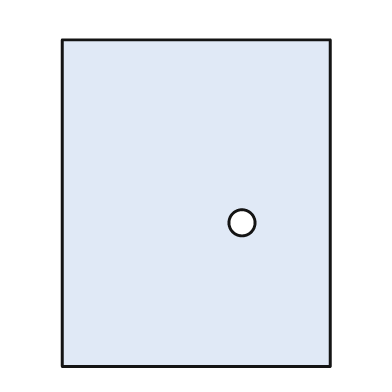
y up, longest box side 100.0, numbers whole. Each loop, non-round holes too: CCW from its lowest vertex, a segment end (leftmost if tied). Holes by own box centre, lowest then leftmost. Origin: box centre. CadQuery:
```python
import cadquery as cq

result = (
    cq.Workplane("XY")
    .moveTo(-41.0, -50.0)
    .lineTo(41.0, -50.0)
    .lineTo(41.0, 50.0)
    .lineTo(-41.0, 50.0)
    .close()
    .moveTo(14.0, -6.0)
    .circle(4.0)
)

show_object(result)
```